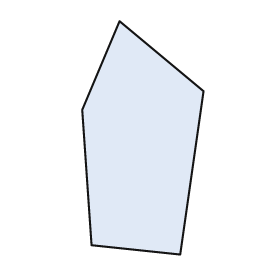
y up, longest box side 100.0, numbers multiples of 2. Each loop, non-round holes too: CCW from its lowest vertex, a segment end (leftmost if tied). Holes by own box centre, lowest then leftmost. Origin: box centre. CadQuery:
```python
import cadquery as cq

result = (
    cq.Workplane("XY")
    .moveTo(16.0, -50.0)
    .lineTo(26.0, 20.0)
    .lineTo(-10.0, 50.0)
    .lineTo(-26.0, 12.0)
    .lineTo(-22.0, -46.0)
    .close()
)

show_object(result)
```